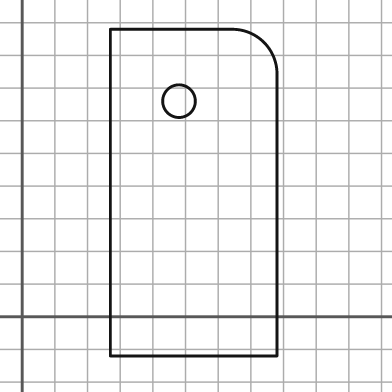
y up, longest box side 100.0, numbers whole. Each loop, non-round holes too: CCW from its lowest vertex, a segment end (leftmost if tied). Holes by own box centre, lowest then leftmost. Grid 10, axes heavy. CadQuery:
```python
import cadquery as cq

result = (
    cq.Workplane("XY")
    .moveTo(27.0, -12.0)
    .lineTo(78.0, -12.0)
    .lineTo(78.0, 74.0)
    .threePointArc((74.0, 84.0), (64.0, 88.0))
    .lineTo(27.0, 88.0)
    .close()
    .moveTo(48.0, 66.0)
    .circle(5.0)
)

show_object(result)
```